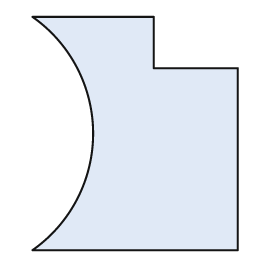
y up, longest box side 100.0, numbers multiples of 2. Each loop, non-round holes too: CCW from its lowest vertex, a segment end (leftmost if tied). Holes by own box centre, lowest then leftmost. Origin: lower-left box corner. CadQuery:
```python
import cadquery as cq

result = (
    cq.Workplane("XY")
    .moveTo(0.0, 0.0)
    .lineTo(88.0, 0.0)
    .lineTo(88.0, 78.0)
    .lineTo(52.0, 78.0)
    .lineTo(52.0, 100.0)
    .lineTo(0.0, 100.0)
    .threePointArc((26.0, 50.0), (0.0, 0.0))
    .close()
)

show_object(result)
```